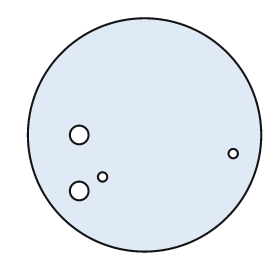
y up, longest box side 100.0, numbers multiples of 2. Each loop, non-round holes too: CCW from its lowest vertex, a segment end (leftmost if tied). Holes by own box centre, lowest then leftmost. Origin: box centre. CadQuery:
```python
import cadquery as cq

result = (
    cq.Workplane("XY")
    .moveTo(0.0, 0.0)
    .circle(50.0)
    .moveTo(-28.0, -24.0)
    .circle(4.0)
    .moveTo(-18.0, -18.0)
    .circle(2.0)
    .moveTo(38.0, -8.0)
    .circle(2.0)
    .moveTo(-28.0, 0.0)
    .circle(4.0)
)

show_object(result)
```